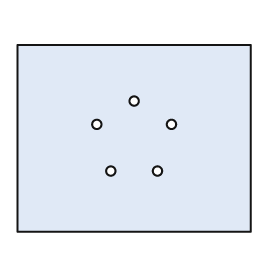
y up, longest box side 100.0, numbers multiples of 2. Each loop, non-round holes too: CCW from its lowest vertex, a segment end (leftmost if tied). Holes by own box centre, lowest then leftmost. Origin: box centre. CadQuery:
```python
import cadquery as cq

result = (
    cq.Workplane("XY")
    .moveTo(-50.0, -40.0)
    .lineTo(50.0, -40.0)
    .lineTo(50.0, 40.0)
    .lineTo(-50.0, 40.0)
    .close()
    .moveTo(-10.0, -14.0)
    .circle(2.0)
    .moveTo(10.0, -14.0)
    .circle(2.0)
    .moveTo(-16.0, 6.0)
    .circle(2.0)
    .moveTo(16.0, 6.0)
    .circle(2.0)
    .moveTo(0.0, 16.0)
    .circle(2.0)
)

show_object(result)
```